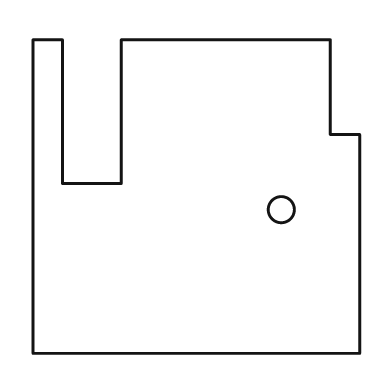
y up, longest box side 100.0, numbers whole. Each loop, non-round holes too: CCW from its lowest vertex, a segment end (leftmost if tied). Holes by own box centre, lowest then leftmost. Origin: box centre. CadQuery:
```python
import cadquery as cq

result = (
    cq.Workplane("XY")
    .moveTo(-50.0, -48.0)
    .lineTo(50.0, -48.0)
    .lineTo(50.0, 19.0)
    .lineTo(41.0, 19.0)
    .lineTo(41.0, 48.0)
    .lineTo(-23.0, 48.0)
    .lineTo(-23.0, 4.0)
    .lineTo(-41.0, 4.0)
    .lineTo(-41.0, 48.0)
    .lineTo(-50.0, 48.0)
    .close()
    .moveTo(26.0, -4.0)
    .circle(4.0)
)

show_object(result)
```